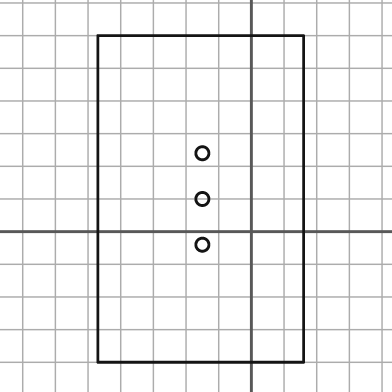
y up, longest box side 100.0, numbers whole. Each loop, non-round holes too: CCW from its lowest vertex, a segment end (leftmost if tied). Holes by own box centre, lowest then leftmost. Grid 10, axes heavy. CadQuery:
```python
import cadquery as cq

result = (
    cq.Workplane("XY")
    .moveTo(-47.0, -40.0)
    .lineTo(16.0, -40.0)
    .lineTo(16.0, 60.0)
    .lineTo(-47.0, 60.0)
    .close()
    .moveTo(-15.0, -4.0)
    .circle(2.0)
    .moveTo(-15.0, 10.0)
    .circle(2.0)
    .moveTo(-15.0, 24.0)
    .circle(2.0)
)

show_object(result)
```